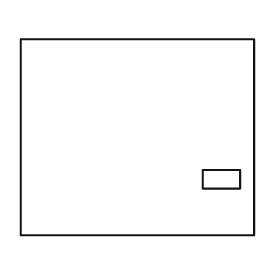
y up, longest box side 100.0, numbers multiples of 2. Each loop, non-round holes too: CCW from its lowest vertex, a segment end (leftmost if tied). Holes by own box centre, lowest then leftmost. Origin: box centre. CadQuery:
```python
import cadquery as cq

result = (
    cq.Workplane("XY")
    .moveTo(-50.0, -42.0)
    .lineTo(50.0, -42.0)
    .lineTo(50.0, 42.0)
    .lineTo(-50.0, 42.0)
    .close()
    .moveTo(28.0, -22.0)
    .lineTo(44.0, -22.0)
    .lineTo(44.0, -14.0)
    .lineTo(28.0, -14.0)
    .close()
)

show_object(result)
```